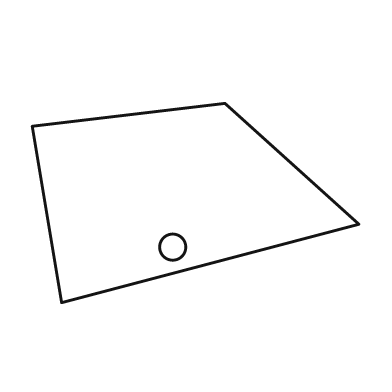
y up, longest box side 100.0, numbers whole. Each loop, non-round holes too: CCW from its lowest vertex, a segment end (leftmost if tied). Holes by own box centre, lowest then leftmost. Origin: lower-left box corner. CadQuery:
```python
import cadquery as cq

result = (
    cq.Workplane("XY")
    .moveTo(9.0, 0.0)
    .lineTo(100.0, 24.0)
    .lineTo(59.0, 61.0)
    .lineTo(0.0, 54.0)
    .close()
    .moveTo(43.0, 17.0)
    .circle(4.0)
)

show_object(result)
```